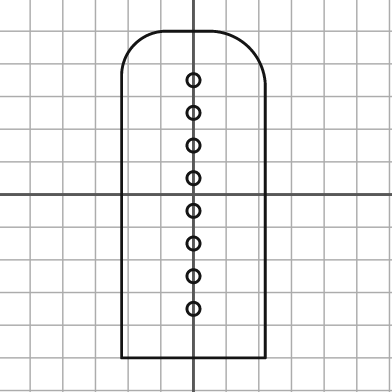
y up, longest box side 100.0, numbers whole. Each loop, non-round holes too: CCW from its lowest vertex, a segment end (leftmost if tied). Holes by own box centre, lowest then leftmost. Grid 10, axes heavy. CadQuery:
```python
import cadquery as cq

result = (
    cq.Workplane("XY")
    .moveTo(-22.0, -50.0)
    .lineTo(22.0, -50.0)
    .lineTo(22.0, 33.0)
    .threePointArc((17.0, 45.0), (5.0, 50.0))
    .lineTo(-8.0, 50.0)
    .threePointArc((-18.0, 46.0), (-22.0, 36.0))
    .close()
    .moveTo(0.0, -35.0)
    .circle(2.0)
    .moveTo(0.0, -25.0)
    .circle(2.0)
    .moveTo(0.0, -15.0)
    .circle(2.0)
    .moveTo(0.0, -5.0)
    .circle(2.0)
    .moveTo(0.0, 5.0)
    .circle(2.0)
    .moveTo(0.0, 15.0)
    .circle(2.0)
    .moveTo(0.0, 25.0)
    .circle(2.0)
    .moveTo(0.0, 35.0)
    .circle(2.0)
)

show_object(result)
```